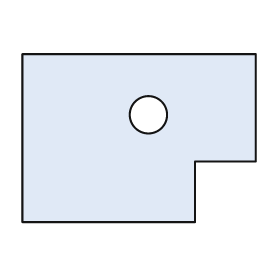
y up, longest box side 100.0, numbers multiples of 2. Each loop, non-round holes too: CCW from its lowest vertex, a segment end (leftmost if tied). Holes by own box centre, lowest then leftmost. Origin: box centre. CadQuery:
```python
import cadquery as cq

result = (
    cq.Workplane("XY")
    .moveTo(-50.0, -36.0)
    .lineTo(24.0, -36.0)
    .lineTo(24.0, -10.0)
    .lineTo(50.0, -10.0)
    .lineTo(50.0, 36.0)
    .lineTo(-50.0, 36.0)
    .close()
    .moveTo(4.0, 10.0)
    .circle(8.0)
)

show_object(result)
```